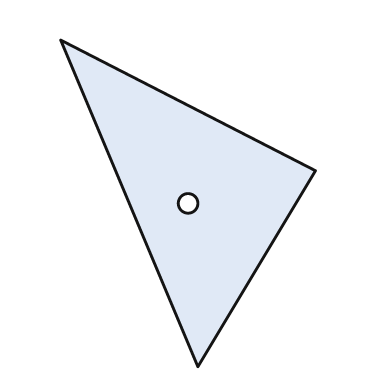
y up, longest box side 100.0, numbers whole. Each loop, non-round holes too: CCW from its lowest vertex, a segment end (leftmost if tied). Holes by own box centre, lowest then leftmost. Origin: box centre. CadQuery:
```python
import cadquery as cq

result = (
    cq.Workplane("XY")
    .moveTo(3.0, -50.0)
    .lineTo(39.0, 10.0)
    .lineTo(-39.0, 50.0)
    .close()
    .moveTo(0.0, 0.0)
    .circle(3.0)
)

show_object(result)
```